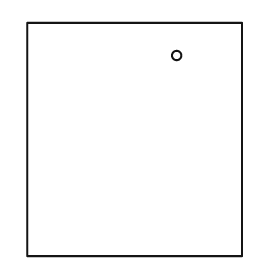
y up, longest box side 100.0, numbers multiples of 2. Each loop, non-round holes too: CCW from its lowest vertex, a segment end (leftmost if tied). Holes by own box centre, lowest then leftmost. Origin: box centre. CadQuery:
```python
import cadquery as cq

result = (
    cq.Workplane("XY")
    .moveTo(-46.0, -50.0)
    .lineTo(46.0, -50.0)
    .lineTo(46.0, 50.0)
    .lineTo(-46.0, 50.0)
    .close()
    .moveTo(18.0, 36.0)
    .circle(2.0)
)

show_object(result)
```